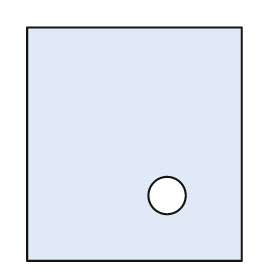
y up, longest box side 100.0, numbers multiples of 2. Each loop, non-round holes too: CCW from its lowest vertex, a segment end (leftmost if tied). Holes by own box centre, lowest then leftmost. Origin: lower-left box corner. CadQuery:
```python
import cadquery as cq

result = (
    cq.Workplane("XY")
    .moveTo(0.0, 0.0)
    .lineTo(92.0, 0.0)
    .lineTo(92.0, 100.0)
    .lineTo(0.0, 100.0)
    .close()
    .moveTo(60.0, 28.0)
    .circle(8.0)
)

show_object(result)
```